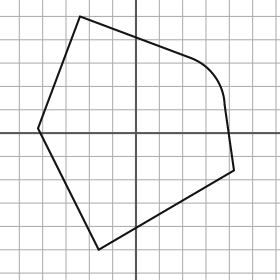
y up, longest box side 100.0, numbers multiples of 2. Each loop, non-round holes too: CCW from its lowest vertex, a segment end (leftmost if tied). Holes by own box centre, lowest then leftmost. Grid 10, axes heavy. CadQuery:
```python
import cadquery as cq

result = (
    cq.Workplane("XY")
    .moveTo(-16.0, -50.0)
    .lineTo(42.0, -16.0)
    .lineTo(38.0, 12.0)
    .threePointArc((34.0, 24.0), (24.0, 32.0))
    .lineTo(-24.0, 50.0)
    .lineTo(-42.0, 2.0)
    .close()
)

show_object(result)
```